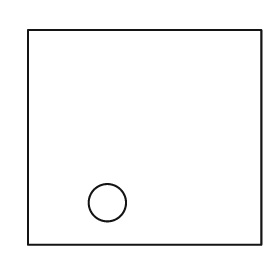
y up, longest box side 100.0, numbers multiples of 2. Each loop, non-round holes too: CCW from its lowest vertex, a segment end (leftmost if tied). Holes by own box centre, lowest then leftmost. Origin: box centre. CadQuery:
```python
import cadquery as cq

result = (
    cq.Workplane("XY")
    .moveTo(-50.0, -46.0)
    .lineTo(50.0, -46.0)
    .lineTo(50.0, 46.0)
    .lineTo(-50.0, 46.0)
    .close()
    .moveTo(-16.0, -28.0)
    .circle(8.0)
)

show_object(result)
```